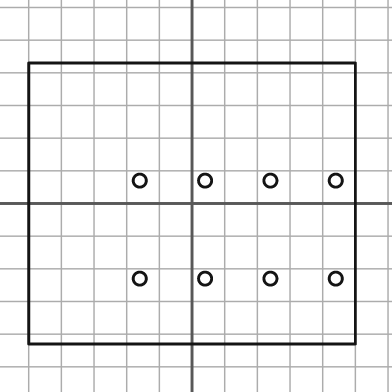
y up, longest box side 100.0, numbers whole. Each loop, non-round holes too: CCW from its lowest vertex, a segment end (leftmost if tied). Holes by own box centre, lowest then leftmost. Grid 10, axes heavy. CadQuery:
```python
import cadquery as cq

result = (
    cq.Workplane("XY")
    .moveTo(-50.0, -43.0)
    .lineTo(50.0, -43.0)
    .lineTo(50.0, 43.0)
    .lineTo(-50.0, 43.0)
    .close()
    .moveTo(-16.0, -23.0)
    .circle(2.0)
    .moveTo(4.0, -23.0)
    .circle(2.0)
    .moveTo(24.0, -23.0)
    .circle(2.0)
    .moveTo(44.0, -23.0)
    .circle(2.0)
    .moveTo(-16.0, 7.0)
    .circle(2.0)
    .moveTo(4.0, 7.0)
    .circle(2.0)
    .moveTo(24.0, 7.0)
    .circle(2.0)
    .moveTo(44.0, 7.0)
    .circle(2.0)
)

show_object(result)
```